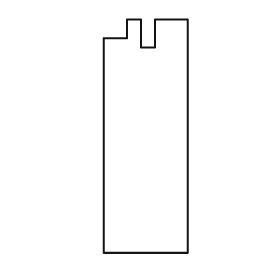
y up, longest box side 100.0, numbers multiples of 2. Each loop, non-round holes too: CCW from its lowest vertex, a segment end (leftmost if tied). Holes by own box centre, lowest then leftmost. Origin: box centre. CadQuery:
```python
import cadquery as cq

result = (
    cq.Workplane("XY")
    .moveTo(-18.0, -50.0)
    .lineTo(18.0, -50.0)
    .lineTo(18.0, 50.0)
    .lineTo(4.0, 50.0)
    .lineTo(4.0, 38.0)
    .lineTo(-2.0, 38.0)
    .lineTo(-2.0, 50.0)
    .lineTo(-8.0, 50.0)
    .lineTo(-8.0, 42.0)
    .lineTo(-18.0, 42.0)
    .close()
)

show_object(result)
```